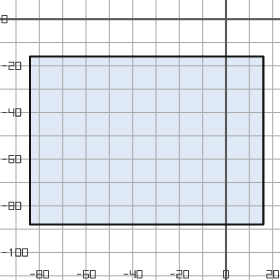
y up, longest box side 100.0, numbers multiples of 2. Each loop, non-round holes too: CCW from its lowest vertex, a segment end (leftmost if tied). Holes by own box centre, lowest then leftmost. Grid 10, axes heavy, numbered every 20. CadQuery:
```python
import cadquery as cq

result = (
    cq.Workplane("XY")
    .moveTo(-84.0, -88.0)
    .lineTo(16.0, -88.0)
    .lineTo(16.0, -16.0)
    .lineTo(-84.0, -16.0)
    .close()
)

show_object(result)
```